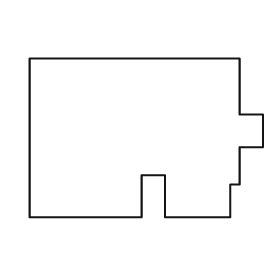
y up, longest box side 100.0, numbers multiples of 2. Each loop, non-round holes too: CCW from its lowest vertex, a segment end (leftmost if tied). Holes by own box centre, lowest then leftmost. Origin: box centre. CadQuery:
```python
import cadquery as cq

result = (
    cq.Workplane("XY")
    .moveTo(-50.0, -34.0)
    .lineTo(-2.0, -34.0)
    .lineTo(-2.0, -16.0)
    .lineTo(8.0, -16.0)
    .lineTo(8.0, -34.0)
    .lineTo(36.0, -34.0)
    .lineTo(36.0, -20.0)
    .lineTo(40.0, -20.0)
    .lineTo(40.0, -4.0)
    .lineTo(50.0, -4.0)
    .lineTo(50.0, 10.0)
    .lineTo(40.0, 10.0)
    .lineTo(40.0, 34.0)
    .lineTo(-50.0, 34.0)
    .close()
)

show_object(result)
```